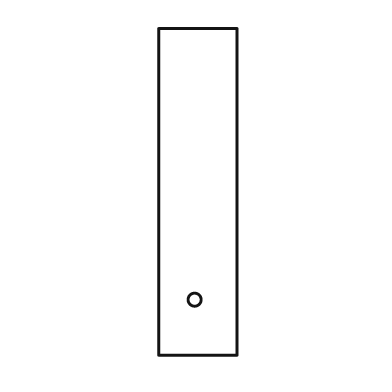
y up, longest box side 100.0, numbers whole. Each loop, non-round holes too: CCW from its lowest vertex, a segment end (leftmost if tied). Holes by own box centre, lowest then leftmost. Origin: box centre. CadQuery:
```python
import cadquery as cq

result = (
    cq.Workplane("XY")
    .moveTo(-12.0, -50.0)
    .lineTo(12.0, -50.0)
    .lineTo(12.0, 50.0)
    .lineTo(-12.0, 50.0)
    .close()
    .moveTo(-1.0, -33.0)
    .circle(2.0)
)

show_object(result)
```